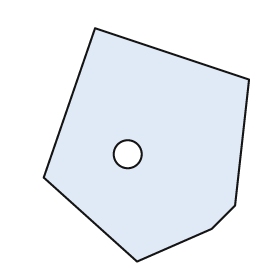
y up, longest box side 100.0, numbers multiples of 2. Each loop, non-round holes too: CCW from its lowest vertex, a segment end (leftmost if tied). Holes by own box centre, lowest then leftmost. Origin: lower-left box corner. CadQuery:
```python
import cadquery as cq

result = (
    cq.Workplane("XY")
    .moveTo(40.0, 0.0)
    .lineTo(72.0, 14.0)
    .lineTo(82.0, 24.0)
    .lineTo(88.0, 78.0)
    .lineTo(22.0, 100.0)
    .lineTo(0.0, 36.0)
    .close()
    .moveTo(36.0, 46.0)
    .circle(6.0)
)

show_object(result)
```